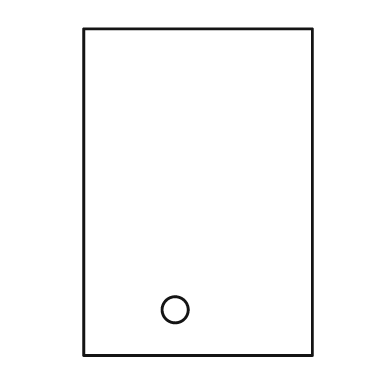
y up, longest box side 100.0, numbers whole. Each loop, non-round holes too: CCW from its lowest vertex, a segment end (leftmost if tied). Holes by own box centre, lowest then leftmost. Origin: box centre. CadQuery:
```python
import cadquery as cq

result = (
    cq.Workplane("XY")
    .moveTo(-35.0, -50.0)
    .lineTo(35.0, -50.0)
    .lineTo(35.0, 50.0)
    .lineTo(-35.0, 50.0)
    .close()
    .moveTo(-7.0, -36.0)
    .circle(4.0)
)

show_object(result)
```